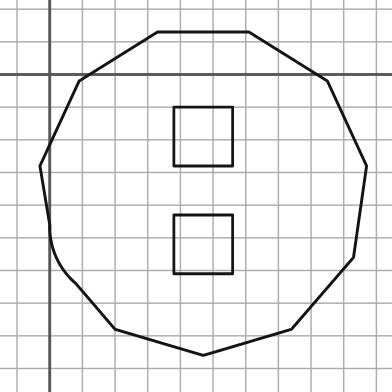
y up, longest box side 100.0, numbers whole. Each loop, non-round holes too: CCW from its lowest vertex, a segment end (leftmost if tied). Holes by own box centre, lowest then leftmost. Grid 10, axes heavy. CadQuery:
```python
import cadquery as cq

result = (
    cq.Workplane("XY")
    .moveTo(47.0, -86.0)
    .lineTo(74.0, -78.0)
    .lineTo(93.0, -56.0)
    .lineTo(97.0, -28.0)
    .lineTo(85.0, -2.0)
    .lineTo(61.0, 13.0)
    .lineTo(33.0, 13.0)
    .lineTo(9.0, -2.0)
    .lineTo(-3.0, -28.0)
    .lineTo(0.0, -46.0)
    .threePointArc((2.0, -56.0), (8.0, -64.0))
    .lineTo(20.0, -78.0)
    .close()
    .moveTo(38.0, -61.0)
    .lineTo(56.0, -61.0)
    .lineTo(56.0, -43.0)
    .lineTo(38.0, -43.0)
    .close()
    .moveTo(38.0, -28.0)
    .lineTo(56.0, -28.0)
    .lineTo(56.0, -10.0)
    .lineTo(38.0, -10.0)
    .close()
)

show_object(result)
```